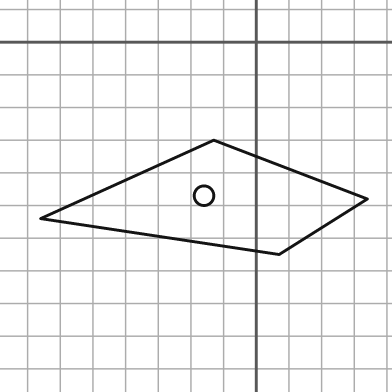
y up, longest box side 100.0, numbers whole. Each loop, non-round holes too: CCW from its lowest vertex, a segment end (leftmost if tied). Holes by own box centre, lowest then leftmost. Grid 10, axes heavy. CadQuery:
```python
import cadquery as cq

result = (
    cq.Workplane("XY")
    .moveTo(7.0, -65.0)
    .lineTo(34.0, -48.0)
    .lineTo(-13.0, -30.0)
    .lineTo(-66.0, -54.0)
    .close()
    .moveTo(-16.0, -47.0)
    .circle(3.0)
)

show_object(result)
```